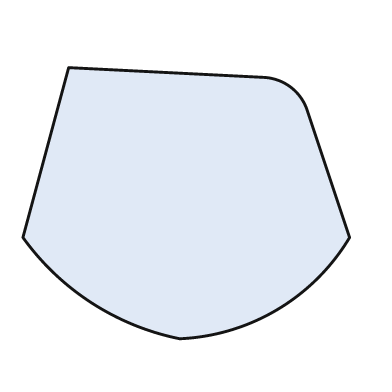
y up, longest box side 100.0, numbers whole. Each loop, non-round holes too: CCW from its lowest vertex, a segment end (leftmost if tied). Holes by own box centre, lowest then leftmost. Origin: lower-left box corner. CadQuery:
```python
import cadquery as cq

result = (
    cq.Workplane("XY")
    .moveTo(48.0, 0.0)
    .threePointArc((78.0, 9.0), (100.0, 31.0))
    .lineTo(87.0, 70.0)
    .threePointArc((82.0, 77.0), (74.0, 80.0))
    .lineTo(14.0, 83.0)
    .lineTo(0.0, 31.0)
    .threePointArc((21.0, 11.0), (48.0, 0.0))
    .close()
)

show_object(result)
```